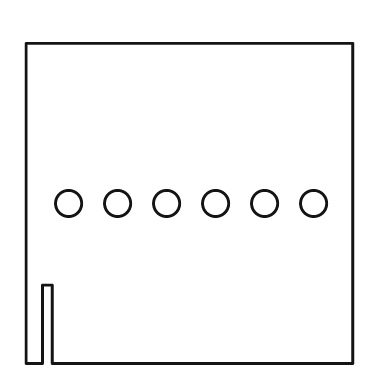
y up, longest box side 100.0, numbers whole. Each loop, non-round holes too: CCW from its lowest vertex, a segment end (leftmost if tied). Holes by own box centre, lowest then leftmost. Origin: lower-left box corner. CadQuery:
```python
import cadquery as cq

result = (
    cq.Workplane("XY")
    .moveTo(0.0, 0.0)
    .lineTo(5.0, 0.0)
    .lineTo(5.0, 24.0)
    .lineTo(8.0, 24.0)
    .lineTo(8.0, 0.0)
    .lineTo(100.0, 0.0)
    .lineTo(100.0, 98.0)
    .lineTo(0.0, 98.0)
    .close()
    .moveTo(13.0, 49.0)
    .circle(4.0)
    .moveTo(28.0, 49.0)
    .circle(4.0)
    .moveTo(43.0, 49.0)
    .circle(4.0)
    .moveTo(58.0, 49.0)
    .circle(4.0)
    .moveTo(73.0, 49.0)
    .circle(4.0)
    .moveTo(88.0, 49.0)
    .circle(4.0)
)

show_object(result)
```